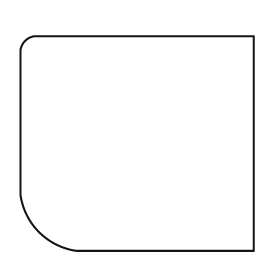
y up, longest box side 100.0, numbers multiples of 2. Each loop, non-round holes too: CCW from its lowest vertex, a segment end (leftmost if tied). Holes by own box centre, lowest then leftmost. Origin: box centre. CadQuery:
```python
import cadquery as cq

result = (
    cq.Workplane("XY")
    .moveTo(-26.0, -46.0)
    .lineTo(50.0, -46.0)
    .lineTo(50.0, 46.0)
    .lineTo(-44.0, 46.0)
    .threePointArc((-48.0, 44.0), (-50.0, 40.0))
    .lineTo(-50.0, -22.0)
    .threePointArc((-42.0, -38.0), (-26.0, -46.0))
    .close()
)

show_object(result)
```